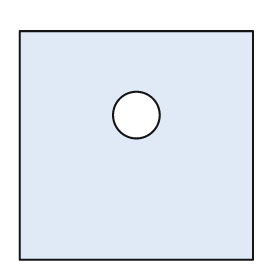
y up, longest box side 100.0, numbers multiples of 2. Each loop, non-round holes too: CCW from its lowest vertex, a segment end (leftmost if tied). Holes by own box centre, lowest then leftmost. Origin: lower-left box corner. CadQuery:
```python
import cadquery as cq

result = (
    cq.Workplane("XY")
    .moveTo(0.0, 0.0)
    .lineTo(100.0, 0.0)
    .lineTo(100.0, 98.0)
    .lineTo(0.0, 98.0)
    .close()
    .moveTo(50.0, 62.0)
    .circle(10.0)
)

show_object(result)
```